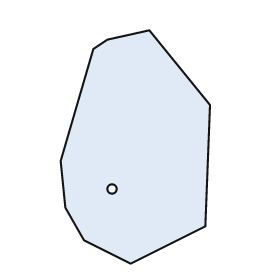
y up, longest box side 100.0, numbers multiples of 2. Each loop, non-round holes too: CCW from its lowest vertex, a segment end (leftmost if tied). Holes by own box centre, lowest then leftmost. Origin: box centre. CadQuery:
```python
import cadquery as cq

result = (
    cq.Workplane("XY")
    .moveTo(-2.0, -50.0)
    .lineTo(30.0, -34.0)
    .lineTo(32.0, 18.0)
    .lineTo(6.0, 50.0)
    .lineTo(-12.0, 46.0)
    .lineTo(-18.0, 42.0)
    .lineTo(-32.0, -6.0)
    .lineTo(-30.0, -26.0)
    .lineTo(-22.0, -40.0)
    .close()
    .moveTo(-10.0, -18.0)
    .circle(2.0)
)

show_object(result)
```